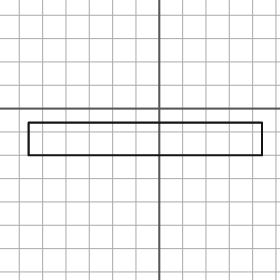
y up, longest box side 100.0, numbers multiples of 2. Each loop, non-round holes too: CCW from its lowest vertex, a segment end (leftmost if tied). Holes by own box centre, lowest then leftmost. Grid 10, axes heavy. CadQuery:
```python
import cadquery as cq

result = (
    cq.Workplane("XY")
    .moveTo(-56.0, -20.0)
    .lineTo(44.0, -20.0)
    .lineTo(44.0, -6.0)
    .lineTo(-56.0, -6.0)
    .close()
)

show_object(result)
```